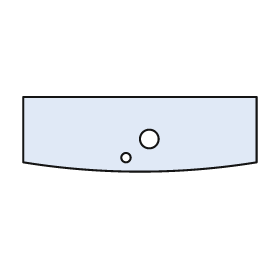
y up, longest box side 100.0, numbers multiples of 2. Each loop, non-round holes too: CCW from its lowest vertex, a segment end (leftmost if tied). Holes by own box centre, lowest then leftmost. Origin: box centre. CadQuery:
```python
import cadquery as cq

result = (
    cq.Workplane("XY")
    .moveTo(-50.0, -12.0)
    .threePointArc((0.0, -16.0), (50.0, -12.0))
    .lineTo(50.0, 16.0)
    .lineTo(-50.0, 16.0)
    .close()
    .moveTo(-6.0, -10.0)
    .circle(2.0)
    .moveTo(4.0, -2.0)
    .circle(4.0)
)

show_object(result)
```